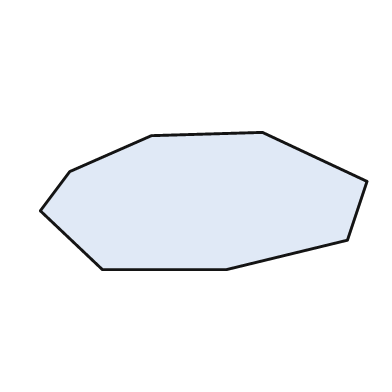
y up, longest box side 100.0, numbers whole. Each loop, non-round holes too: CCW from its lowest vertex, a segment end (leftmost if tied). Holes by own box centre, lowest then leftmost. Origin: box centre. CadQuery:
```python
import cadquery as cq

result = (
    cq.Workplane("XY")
    .moveTo(-31.0, -21.0)
    .lineTo(7.0, -21.0)
    .lineTo(44.0, -12.0)
    .lineTo(50.0, 6.0)
    .lineTo(18.0, 21.0)
    .lineTo(-16.0, 20.0)
    .lineTo(-41.0, 9.0)
    .lineTo(-50.0, -3.0)
    .close()
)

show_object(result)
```